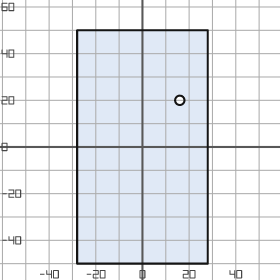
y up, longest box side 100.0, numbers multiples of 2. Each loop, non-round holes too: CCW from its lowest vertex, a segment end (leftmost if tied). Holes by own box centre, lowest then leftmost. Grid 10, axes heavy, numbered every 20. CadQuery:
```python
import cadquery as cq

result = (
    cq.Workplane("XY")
    .moveTo(-28.0, -50.0)
    .lineTo(28.0, -50.0)
    .lineTo(28.0, 50.0)
    .lineTo(-28.0, 50.0)
    .close()
    .moveTo(16.0, 20.0)
    .circle(2.0)
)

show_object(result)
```